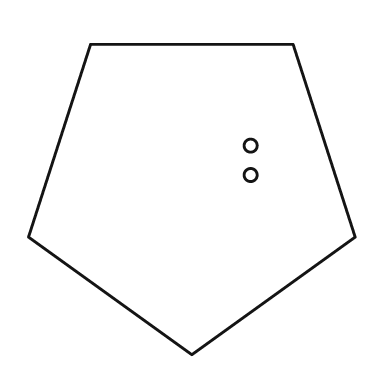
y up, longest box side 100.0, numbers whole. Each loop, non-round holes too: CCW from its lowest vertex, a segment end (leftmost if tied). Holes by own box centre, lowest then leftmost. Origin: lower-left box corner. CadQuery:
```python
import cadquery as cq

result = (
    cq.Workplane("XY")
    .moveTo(50.0, 0.0)
    .lineTo(100.0, 36.0)
    .lineTo(81.0, 95.0)
    .lineTo(19.0, 95.0)
    .lineTo(0.0, 36.0)
    .close()
    .moveTo(68.0, 55.0)
    .circle(2.0)
    .moveTo(68.0, 64.0)
    .circle(2.0)
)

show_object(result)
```